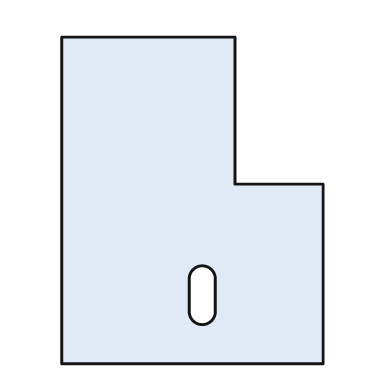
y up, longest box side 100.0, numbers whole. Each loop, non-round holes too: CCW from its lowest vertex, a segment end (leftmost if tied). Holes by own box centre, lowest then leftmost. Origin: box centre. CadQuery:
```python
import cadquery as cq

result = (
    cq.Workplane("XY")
    .moveTo(-40.0, -50.0)
    .lineTo(40.0, -50.0)
    .lineTo(40.0, 5.0)
    .lineTo(13.0, 5.0)
    .lineTo(13.0, 50.0)
    .lineTo(-40.0, 50.0)
    .close()
    .moveTo(-1.0, -34.0)
    .threePointArc((3.0, -38.0), (7.0, -34.0))
    .lineTo(7.0, -24.0)
    .threePointArc((3.0, -20.0), (-1.0, -24.0))
    .close()
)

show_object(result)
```